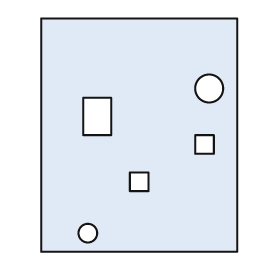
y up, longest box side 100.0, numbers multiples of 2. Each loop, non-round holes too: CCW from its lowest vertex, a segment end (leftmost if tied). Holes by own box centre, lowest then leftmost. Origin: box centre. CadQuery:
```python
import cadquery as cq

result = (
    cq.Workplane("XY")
    .moveTo(-42.0, -50.0)
    .lineTo(42.0, -50.0)
    .lineTo(42.0, 50.0)
    .lineTo(-42.0, 50.0)
    .close()
    .moveTo(-22.0, -42.0)
    .circle(4.0)
    .moveTo(-4.0, -24.0)
    .lineTo(4.0, -24.0)
    .lineTo(4.0, -16.0)
    .lineTo(-4.0, -16.0)
    .close()
    .moveTo(24.0, -8.0)
    .lineTo(32.0, -8.0)
    .lineTo(32.0, 0.0)
    .lineTo(24.0, 0.0)
    .close()
    .moveTo(-24.0, 0.0)
    .lineTo(-12.0, 0.0)
    .lineTo(-12.0, 16.0)
    .lineTo(-24.0, 16.0)
    .close()
    .moveTo(30.0, 20.0)
    .circle(6.0)
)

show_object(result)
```